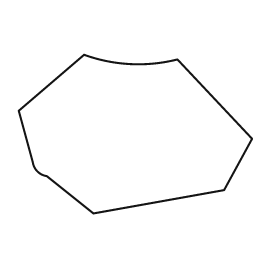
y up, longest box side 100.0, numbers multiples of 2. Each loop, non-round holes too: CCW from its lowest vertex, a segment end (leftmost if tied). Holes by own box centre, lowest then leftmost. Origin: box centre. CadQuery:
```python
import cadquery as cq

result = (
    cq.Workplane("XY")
    .moveTo(-18.0, -34.0)
    .lineTo(38.0, -24.0)
    .lineTo(50.0, -2.0)
    .lineTo(18.0, 32.0)
    .threePointArc((-2.0, 30.0), (-22.0, 34.0))
    .lineTo(-50.0, 10.0)
    .lineTo(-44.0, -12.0)
    .threePointArc((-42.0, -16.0), (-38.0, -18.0))
    .close()
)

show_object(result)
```